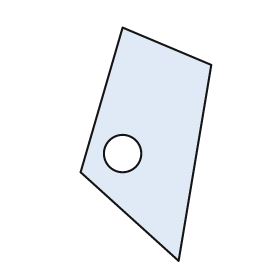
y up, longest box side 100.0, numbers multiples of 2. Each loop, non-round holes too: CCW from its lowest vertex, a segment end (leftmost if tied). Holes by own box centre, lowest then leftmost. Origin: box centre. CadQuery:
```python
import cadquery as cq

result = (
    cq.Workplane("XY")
    .moveTo(14.0, -50.0)
    .lineTo(28.0, 34.0)
    .lineTo(-10.0, 50.0)
    .lineTo(-28.0, -12.0)
    .close()
    .moveTo(-10.0, -4.0)
    .circle(8.0)
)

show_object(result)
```